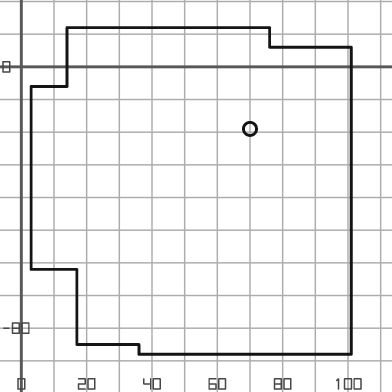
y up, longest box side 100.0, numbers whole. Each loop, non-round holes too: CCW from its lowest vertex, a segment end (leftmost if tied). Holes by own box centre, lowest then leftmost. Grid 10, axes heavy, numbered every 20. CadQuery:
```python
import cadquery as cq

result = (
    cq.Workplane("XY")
    .moveTo(36.0, -88.0)
    .lineTo(101.0, -88.0)
    .lineTo(101.0, 6.0)
    .lineTo(76.0, 6.0)
    .lineTo(76.0, 12.0)
    .lineTo(14.0, 12.0)
    .lineTo(14.0, -6.0)
    .lineTo(3.0, -6.0)
    .lineTo(3.0, -62.0)
    .lineTo(17.0, -62.0)
    .lineTo(17.0, -85.0)
    .lineTo(36.0, -85.0)
    .close()
    .moveTo(70.0, -19.0)
    .circle(2.0)
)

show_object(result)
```